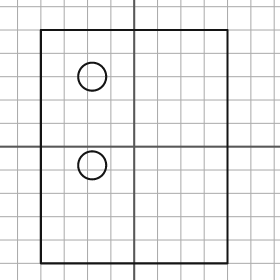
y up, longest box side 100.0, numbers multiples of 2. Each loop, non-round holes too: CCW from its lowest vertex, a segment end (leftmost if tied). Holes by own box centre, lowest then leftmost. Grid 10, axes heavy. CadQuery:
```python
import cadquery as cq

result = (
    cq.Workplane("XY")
    .moveTo(-40.0, -50.0)
    .lineTo(40.0, -50.0)
    .lineTo(40.0, 50.0)
    .lineTo(-40.0, 50.0)
    .close()
    .moveTo(-18.0, -8.0)
    .circle(6.0)
    .moveTo(-18.0, 30.0)
    .circle(6.0)
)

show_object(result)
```